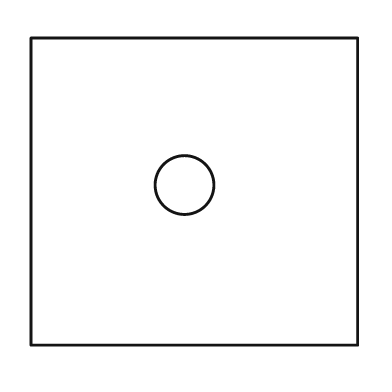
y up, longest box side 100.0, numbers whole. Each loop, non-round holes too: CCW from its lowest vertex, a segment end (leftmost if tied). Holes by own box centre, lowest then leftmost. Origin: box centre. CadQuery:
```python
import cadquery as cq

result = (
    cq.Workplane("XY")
    .moveTo(-50.0, -47.0)
    .lineTo(50.0, -47.0)
    .lineTo(50.0, 47.0)
    .lineTo(-50.0, 47.0)
    .close()
    .moveTo(-3.0, 2.0)
    .circle(9.0)
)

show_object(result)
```